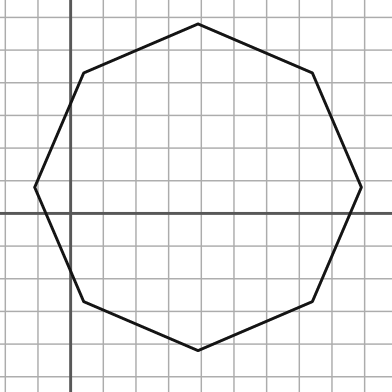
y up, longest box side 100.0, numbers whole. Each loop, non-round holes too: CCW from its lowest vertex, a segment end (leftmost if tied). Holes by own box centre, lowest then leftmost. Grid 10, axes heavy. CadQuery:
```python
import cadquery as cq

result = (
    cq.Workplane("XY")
    .moveTo(39.0, -42.0)
    .lineTo(74.0, -27.0)
    .lineTo(89.0, 8.0)
    .lineTo(74.0, 43.0)
    .lineTo(39.0, 58.0)
    .lineTo(4.0, 43.0)
    .lineTo(-11.0, 8.0)
    .lineTo(4.0, -27.0)
    .close()
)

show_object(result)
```